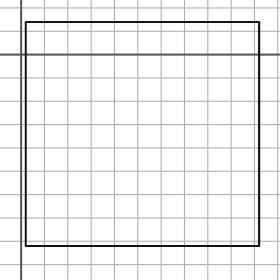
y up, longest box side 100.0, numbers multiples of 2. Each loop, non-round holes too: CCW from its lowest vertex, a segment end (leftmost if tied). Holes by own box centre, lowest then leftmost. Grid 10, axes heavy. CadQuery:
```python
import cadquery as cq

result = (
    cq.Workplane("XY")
    .moveTo(2.0, -82.0)
    .lineTo(102.0, -82.0)
    .lineTo(102.0, 14.0)
    .lineTo(2.0, 14.0)
    .close()
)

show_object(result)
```